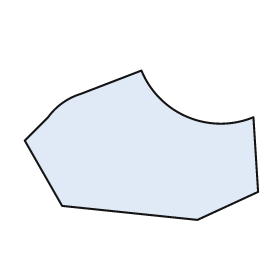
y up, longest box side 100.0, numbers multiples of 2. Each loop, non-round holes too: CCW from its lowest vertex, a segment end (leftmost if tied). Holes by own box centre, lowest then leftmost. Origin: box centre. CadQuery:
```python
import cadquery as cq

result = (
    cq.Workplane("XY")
    .moveTo(24.0, -32.0)
    .lineTo(50.0, -20.0)
    .lineTo(48.0, 12.0)
    .threePointArc((20.0, 12.0), (0.0, 32.0))
    .lineTo(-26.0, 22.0)
    .threePointArc((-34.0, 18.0), (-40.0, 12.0))
    .lineTo(-50.0, 2.0)
    .lineTo(-34.0, -26.0)
    .close()
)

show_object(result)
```